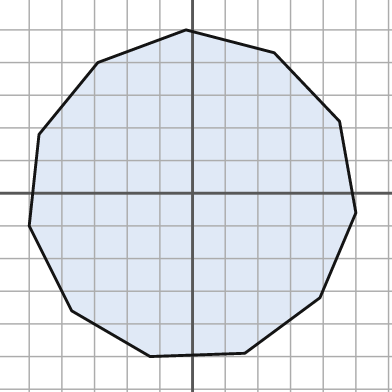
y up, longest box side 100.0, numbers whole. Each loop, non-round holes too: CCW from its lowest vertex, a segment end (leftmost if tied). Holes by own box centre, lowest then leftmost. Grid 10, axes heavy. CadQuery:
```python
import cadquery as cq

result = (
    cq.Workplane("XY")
    .moveTo(-13.0, -50.0)
    .lineTo(16.0, -49.0)
    .lineTo(39.0, -32.0)
    .lineTo(50.0, -6.0)
    .lineTo(45.0, 22.0)
    .lineTo(25.0, 43.0)
    .lineTo(-2.0, 50.0)
    .lineTo(-29.0, 40.0)
    .lineTo(-47.0, 18.0)
    .lineTo(-50.0, -10.0)
    .lineTo(-37.0, -36.0)
    .close()
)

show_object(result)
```